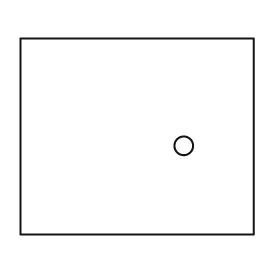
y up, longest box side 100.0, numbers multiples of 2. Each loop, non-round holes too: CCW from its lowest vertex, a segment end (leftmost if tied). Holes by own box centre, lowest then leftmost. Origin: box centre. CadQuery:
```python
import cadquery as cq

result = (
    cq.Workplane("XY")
    .moveTo(-50.0, -42.0)
    .lineTo(50.0, -42.0)
    .lineTo(50.0, 42.0)
    .lineTo(-50.0, 42.0)
    .close()
    .moveTo(20.0, -4.0)
    .circle(4.0)
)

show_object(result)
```